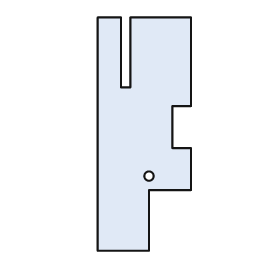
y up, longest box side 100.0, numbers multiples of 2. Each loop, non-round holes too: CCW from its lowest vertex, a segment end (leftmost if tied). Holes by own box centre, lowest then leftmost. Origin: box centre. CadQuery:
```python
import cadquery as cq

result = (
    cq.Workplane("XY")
    .moveTo(-20.0, -50.0)
    .lineTo(2.0, -50.0)
    .lineTo(2.0, -24.0)
    .lineTo(20.0, -24.0)
    .lineTo(20.0, -6.0)
    .lineTo(12.0, -6.0)
    .lineTo(12.0, 12.0)
    .lineTo(20.0, 12.0)
    .lineTo(20.0, 50.0)
    .lineTo(-6.0, 50.0)
    .lineTo(-6.0, 20.0)
    .lineTo(-10.0, 20.0)
    .lineTo(-10.0, 50.0)
    .lineTo(-20.0, 50.0)
    .close()
    .moveTo(2.0, -18.0)
    .circle(2.0)
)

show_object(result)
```